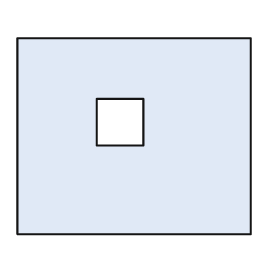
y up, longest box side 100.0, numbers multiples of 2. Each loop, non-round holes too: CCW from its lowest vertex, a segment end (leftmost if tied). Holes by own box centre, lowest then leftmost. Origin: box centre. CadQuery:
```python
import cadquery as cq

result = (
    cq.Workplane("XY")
    .moveTo(-50.0, -42.0)
    .lineTo(50.0, -42.0)
    .lineTo(50.0, 42.0)
    .lineTo(-50.0, 42.0)
    .close()
    .moveTo(-16.0, -4.0)
    .lineTo(4.0, -4.0)
    .lineTo(4.0, 16.0)
    .lineTo(-16.0, 16.0)
    .close()
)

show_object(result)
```